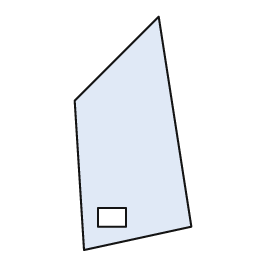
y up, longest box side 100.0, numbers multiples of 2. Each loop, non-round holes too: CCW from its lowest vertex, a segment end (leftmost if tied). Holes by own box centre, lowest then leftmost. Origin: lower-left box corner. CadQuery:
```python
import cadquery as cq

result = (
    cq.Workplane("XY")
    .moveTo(4.0, 0.0)
    .lineTo(50.0, 10.0)
    .lineTo(36.0, 100.0)
    .lineTo(0.0, 64.0)
    .close()
    .moveTo(10.0, 10.0)
    .lineTo(22.0, 10.0)
    .lineTo(22.0, 18.0)
    .lineTo(10.0, 18.0)
    .close()
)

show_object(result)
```